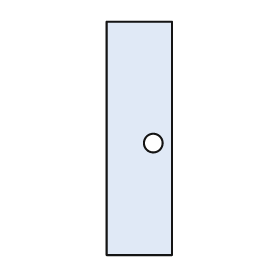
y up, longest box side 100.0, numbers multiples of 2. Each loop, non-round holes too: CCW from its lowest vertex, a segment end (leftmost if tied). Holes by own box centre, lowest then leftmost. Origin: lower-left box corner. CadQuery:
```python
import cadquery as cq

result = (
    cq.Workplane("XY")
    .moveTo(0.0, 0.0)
    .lineTo(28.0, 0.0)
    .lineTo(28.0, 100.0)
    .lineTo(0.0, 100.0)
    .close()
    .moveTo(20.0, 48.0)
    .circle(4.0)
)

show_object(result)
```